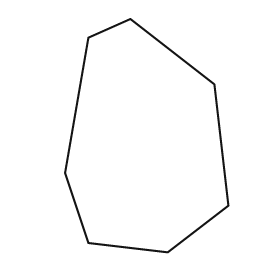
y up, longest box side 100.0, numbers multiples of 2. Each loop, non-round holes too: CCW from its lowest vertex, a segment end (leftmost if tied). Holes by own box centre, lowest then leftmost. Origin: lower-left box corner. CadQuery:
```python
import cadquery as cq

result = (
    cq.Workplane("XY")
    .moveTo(44.0, 0.0)
    .lineTo(70.0, 20.0)
    .lineTo(64.0, 72.0)
    .lineTo(28.0, 100.0)
    .lineTo(10.0, 92.0)
    .lineTo(0.0, 34.0)
    .lineTo(10.0, 4.0)
    .close()
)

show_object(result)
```